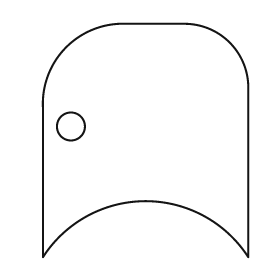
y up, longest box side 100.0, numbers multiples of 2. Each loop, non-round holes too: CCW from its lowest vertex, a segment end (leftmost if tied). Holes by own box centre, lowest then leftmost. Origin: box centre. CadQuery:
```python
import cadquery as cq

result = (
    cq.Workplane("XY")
    .moveTo(-44.0, -50.0)
    .threePointArc((0.0, -26.0), (44.0, -50.0))
    .lineTo(44.0, 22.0)
    .threePointArc((36.0, 42.0), (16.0, 50.0))
    .lineTo(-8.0, 50.0)
    .threePointArc((-34.0, 40.0), (-44.0, 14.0))
    .close()
    .moveTo(-32.0, 6.0)
    .circle(6.0)
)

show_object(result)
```